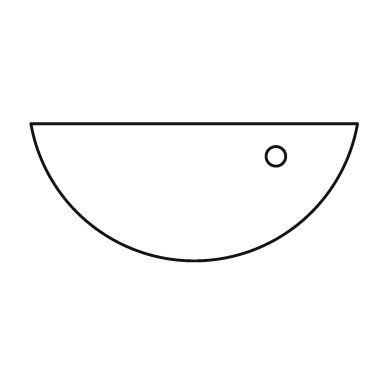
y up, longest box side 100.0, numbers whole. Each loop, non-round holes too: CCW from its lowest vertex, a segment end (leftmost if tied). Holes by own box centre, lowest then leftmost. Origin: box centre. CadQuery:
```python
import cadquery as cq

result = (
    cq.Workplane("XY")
    .moveTo(-50.0, 21.0)
    .threePointArc((0.0, -21.0), (50.0, 21.0))
    .close()
    .moveTo(25.0, 11.0)
    .circle(3.0)
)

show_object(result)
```